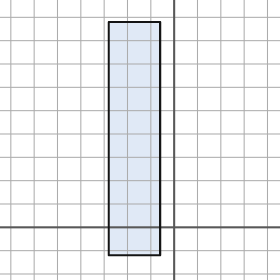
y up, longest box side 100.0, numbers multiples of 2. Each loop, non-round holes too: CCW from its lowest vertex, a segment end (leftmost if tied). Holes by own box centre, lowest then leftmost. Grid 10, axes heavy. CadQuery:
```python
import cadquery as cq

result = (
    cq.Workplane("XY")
    .moveTo(-28.0, -12.0)
    .lineTo(-6.0, -12.0)
    .lineTo(-6.0, 88.0)
    .lineTo(-28.0, 88.0)
    .close()
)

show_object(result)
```